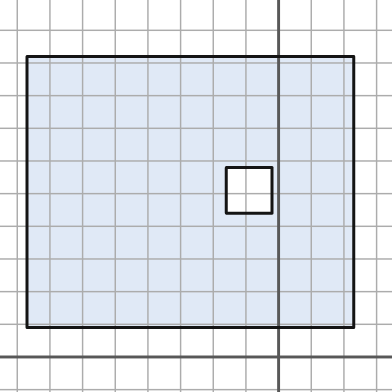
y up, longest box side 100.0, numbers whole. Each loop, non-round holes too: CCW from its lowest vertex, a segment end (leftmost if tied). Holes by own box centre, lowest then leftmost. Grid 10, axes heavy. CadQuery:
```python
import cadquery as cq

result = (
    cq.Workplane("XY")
    .moveTo(-77.0, 9.0)
    .lineTo(23.0, 9.0)
    .lineTo(23.0, 92.0)
    .lineTo(-77.0, 92.0)
    .close()
    .moveTo(-16.0, 44.0)
    .lineTo(-2.0, 44.0)
    .lineTo(-2.0, 58.0)
    .lineTo(-16.0, 58.0)
    .close()
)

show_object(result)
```